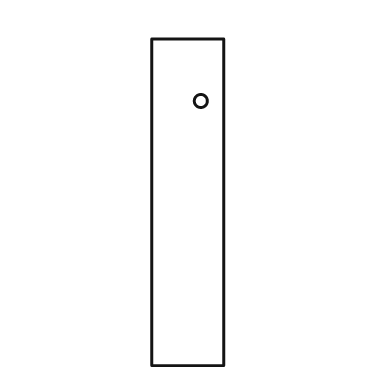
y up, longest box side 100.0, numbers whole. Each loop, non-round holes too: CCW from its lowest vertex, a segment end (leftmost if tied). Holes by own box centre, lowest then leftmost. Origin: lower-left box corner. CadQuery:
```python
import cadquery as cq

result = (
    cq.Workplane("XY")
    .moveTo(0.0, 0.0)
    .lineTo(22.0, 0.0)
    .lineTo(22.0, 100.0)
    .lineTo(0.0, 100.0)
    .close()
    .moveTo(15.0, 81.0)
    .circle(2.0)
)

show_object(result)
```